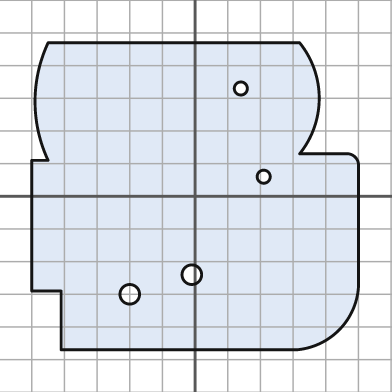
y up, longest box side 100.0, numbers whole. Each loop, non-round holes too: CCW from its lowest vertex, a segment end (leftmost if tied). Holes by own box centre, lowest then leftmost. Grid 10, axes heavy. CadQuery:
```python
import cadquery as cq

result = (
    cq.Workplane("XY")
    .moveTo(-41.0, -47.0)
    .lineTo(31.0, -47.0)
    .threePointArc((44.0, -41.0), (50.0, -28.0))
    .lineTo(50.0, 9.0)
    .threePointArc((49.0, 12.0), (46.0, 13.0))
    .lineTo(32.0, 13.0)
    .threePointArc((38.0, 30.0), (32.0, 47.0))
    .lineTo(-45.0, 47.0)
    .threePointArc((-49.0, 29.0), (-45.0, 11.0))
    .lineTo(-50.0, 11.0)
    .lineTo(-50.0, -29.0)
    .lineTo(-41.0, -29.0)
    .close()
    .moveTo(-20.0, -30.0)
    .circle(3.0)
    .moveTo(-1.0, -24.0)
    .circle(3.0)
    .moveTo(21.0, 6.0)
    .circle(2.0)
    .moveTo(14.0, 33.0)
    .circle(2.0)
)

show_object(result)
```